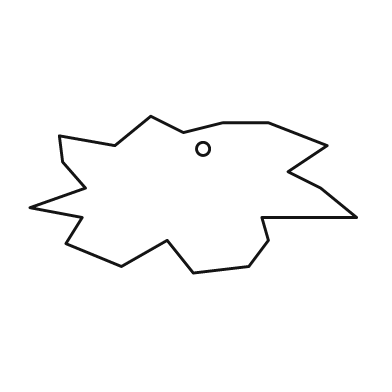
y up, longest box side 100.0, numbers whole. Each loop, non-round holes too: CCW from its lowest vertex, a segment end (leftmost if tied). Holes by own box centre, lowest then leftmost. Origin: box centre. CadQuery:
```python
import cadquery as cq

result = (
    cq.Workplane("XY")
    .moveTo(0.0, -24.0)
    .lineTo(17.0, -22.0)
    .lineTo(23.0, -14.0)
    .lineTo(21.0, -7.0)
    .lineTo(50.0, -7.0)
    .lineTo(39.0, 2.0)
    .lineTo(29.0, 7.0)
    .lineTo(41.0, 15.0)
    .lineTo(23.0, 22.0)
    .lineTo(9.0, 22.0)
    .lineTo(-3.0, 19.0)
    .lineTo(-13.0, 24.0)
    .lineTo(-24.0, 15.0)
    .lineTo(-41.0, 18.0)
    .lineTo(-40.0, 10.0)
    .lineTo(-33.0, 2.0)
    .lineTo(-50.0, -4.0)
    .lineTo(-34.0, -7.0)
    .lineTo(-39.0, -15.0)
    .lineTo(-22.0, -22.0)
    .lineTo(-8.0, -14.0)
    .close()
    .moveTo(3.0, 14.0)
    .circle(2.0)
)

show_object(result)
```